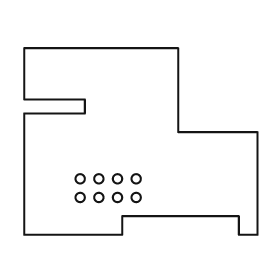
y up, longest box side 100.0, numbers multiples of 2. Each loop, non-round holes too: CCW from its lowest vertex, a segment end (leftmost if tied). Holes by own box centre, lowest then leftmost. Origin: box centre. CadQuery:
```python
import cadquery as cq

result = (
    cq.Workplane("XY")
    .moveTo(-50.0, -40.0)
    .lineTo(-8.0, -40.0)
    .lineTo(-8.0, -32.0)
    .lineTo(42.0, -32.0)
    .lineTo(42.0, -40.0)
    .lineTo(50.0, -40.0)
    .lineTo(50.0, 4.0)
    .lineTo(16.0, 4.0)
    .lineTo(16.0, 40.0)
    .lineTo(-50.0, 40.0)
    .lineTo(-50.0, 18.0)
    .lineTo(-24.0, 18.0)
    .lineTo(-24.0, 12.0)
    .lineTo(-50.0, 12.0)
    .close()
    .moveTo(-26.0, -24.0)
    .circle(2.0)
    .moveTo(-18.0, -24.0)
    .circle(2.0)
    .moveTo(-10.0, -24.0)
    .circle(2.0)
    .moveTo(-2.0, -24.0)
    .circle(2.0)
    .moveTo(-26.0, -16.0)
    .circle(2.0)
    .moveTo(-18.0, -16.0)
    .circle(2.0)
    .moveTo(-10.0, -16.0)
    .circle(2.0)
    .moveTo(-2.0, -16.0)
    .circle(2.0)
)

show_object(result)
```